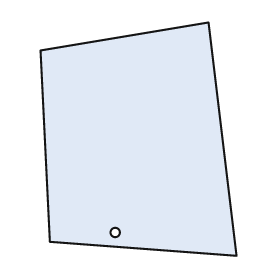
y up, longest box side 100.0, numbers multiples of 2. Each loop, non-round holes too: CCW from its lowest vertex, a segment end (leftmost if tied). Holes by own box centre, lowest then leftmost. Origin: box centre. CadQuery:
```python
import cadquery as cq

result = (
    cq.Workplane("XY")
    .moveTo(42.0, -50.0)
    .lineTo(30.0, 50.0)
    .lineTo(-42.0, 38.0)
    .lineTo(-38.0, -44.0)
    .close()
    .moveTo(-10.0, -40.0)
    .circle(2.0)
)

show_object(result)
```